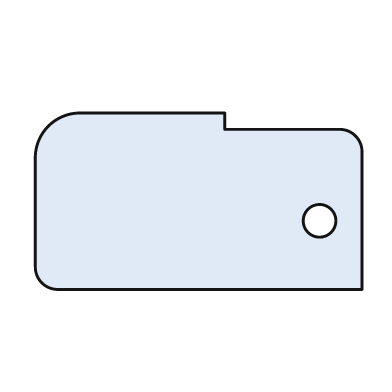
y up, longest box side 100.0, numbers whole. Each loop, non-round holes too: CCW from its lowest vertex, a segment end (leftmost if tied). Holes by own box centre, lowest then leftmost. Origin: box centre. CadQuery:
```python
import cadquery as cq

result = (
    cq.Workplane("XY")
    .moveTo(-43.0, -27.0)
    .lineTo(50.0, -27.0)
    .lineTo(50.0, 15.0)
    .threePointArc((48.0, 20.0), (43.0, 22.0))
    .lineTo(8.0, 22.0)
    .lineTo(8.0, 27.0)
    .lineTo(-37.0, 27.0)
    .threePointArc((-46.0, 23.0), (-50.0, 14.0))
    .lineTo(-50.0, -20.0)
    .threePointArc((-48.0, -25.0), (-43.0, -27.0))
    .close()
    .moveTo(37.0, -6.0)
    .circle(5.0)
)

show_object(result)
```